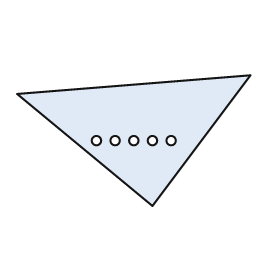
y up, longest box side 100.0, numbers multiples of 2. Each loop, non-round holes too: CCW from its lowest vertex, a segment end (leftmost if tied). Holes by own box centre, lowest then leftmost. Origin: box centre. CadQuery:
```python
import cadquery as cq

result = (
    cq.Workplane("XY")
    .moveTo(8.0, -28.0)
    .lineTo(50.0, 28.0)
    .lineTo(-50.0, 20.0)
    .close()
    .moveTo(-16.0, 0.0)
    .circle(2.0)
    .moveTo(-8.0, 0.0)
    .circle(2.0)
    .moveTo(0.0, 0.0)
    .circle(2.0)
    .moveTo(8.0, 0.0)
    .circle(2.0)
    .moveTo(16.0, 0.0)
    .circle(2.0)
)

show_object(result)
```